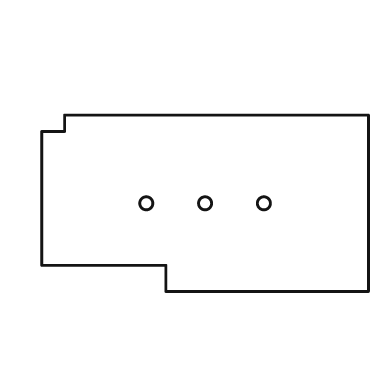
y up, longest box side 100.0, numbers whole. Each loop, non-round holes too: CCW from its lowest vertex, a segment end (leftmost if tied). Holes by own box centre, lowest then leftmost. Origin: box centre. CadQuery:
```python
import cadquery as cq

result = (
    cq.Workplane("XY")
    .moveTo(-12.0, -27.0)
    .lineTo(50.0, -27.0)
    .lineTo(50.0, 27.0)
    .lineTo(-43.0, 27.0)
    .lineTo(-43.0, 22.0)
    .lineTo(-50.0, 22.0)
    .lineTo(-50.0, -19.0)
    .lineTo(-12.0, -19.0)
    .close()
    .moveTo(-18.0, 0.0)
    .circle(2.0)
    .moveTo(0.0, 0.0)
    .circle(2.0)
    .moveTo(18.0, 0.0)
    .circle(2.0)
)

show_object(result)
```